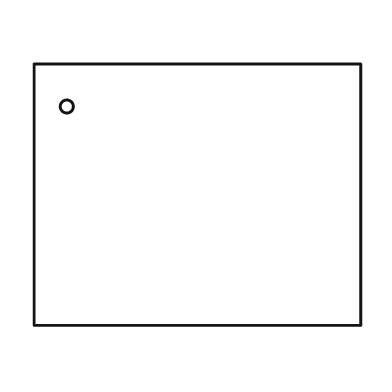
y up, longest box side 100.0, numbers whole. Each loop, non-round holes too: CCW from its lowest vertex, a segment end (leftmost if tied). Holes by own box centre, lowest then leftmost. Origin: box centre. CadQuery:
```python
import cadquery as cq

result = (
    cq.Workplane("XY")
    .moveTo(-50.0, -40.0)
    .lineTo(50.0, -40.0)
    .lineTo(50.0, 40.0)
    .lineTo(-50.0, 40.0)
    .close()
    .moveTo(-40.0, 27.0)
    .circle(2.0)
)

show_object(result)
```